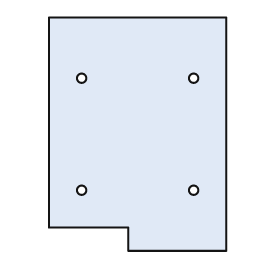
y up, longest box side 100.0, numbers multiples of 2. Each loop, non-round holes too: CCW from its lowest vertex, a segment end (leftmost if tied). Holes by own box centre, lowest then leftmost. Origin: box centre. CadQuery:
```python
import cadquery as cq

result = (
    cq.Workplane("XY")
    .moveTo(-4.0, -50.0)
    .lineTo(38.0, -50.0)
    .lineTo(38.0, 50.0)
    .lineTo(-38.0, 50.0)
    .lineTo(-38.0, -40.0)
    .lineTo(-4.0, -40.0)
    .close()
    .moveTo(-24.0, -24.0)
    .circle(2.0)
    .moveTo(24.0, -24.0)
    .circle(2.0)
    .moveTo(-24.0, 24.0)
    .circle(2.0)
    .moveTo(24.0, 24.0)
    .circle(2.0)
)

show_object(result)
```